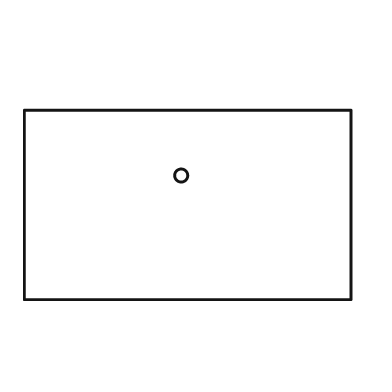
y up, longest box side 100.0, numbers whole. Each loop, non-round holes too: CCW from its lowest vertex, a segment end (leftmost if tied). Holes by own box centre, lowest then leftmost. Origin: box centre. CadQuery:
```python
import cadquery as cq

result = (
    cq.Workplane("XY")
    .moveTo(-50.0, -29.0)
    .lineTo(50.0, -29.0)
    .lineTo(50.0, 29.0)
    .lineTo(-50.0, 29.0)
    .close()
    .moveTo(-2.0, 9.0)
    .circle(2.0)
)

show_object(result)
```